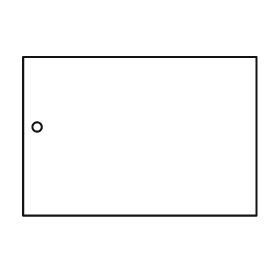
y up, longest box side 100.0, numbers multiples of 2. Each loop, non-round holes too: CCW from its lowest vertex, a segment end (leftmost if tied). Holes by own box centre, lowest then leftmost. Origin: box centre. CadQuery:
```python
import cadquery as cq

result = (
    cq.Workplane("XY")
    .moveTo(-50.0, -34.0)
    .lineTo(50.0, -34.0)
    .lineTo(50.0, 34.0)
    .lineTo(-50.0, 34.0)
    .close()
    .moveTo(-44.0, 4.0)
    .circle(2.0)
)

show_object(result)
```